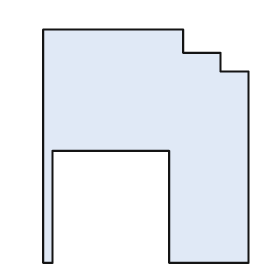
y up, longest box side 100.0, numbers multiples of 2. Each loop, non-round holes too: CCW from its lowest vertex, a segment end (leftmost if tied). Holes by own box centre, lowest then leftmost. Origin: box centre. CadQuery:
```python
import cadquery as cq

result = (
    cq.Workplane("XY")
    .moveTo(-44.0, -50.0)
    .lineTo(-40.0, -50.0)
    .lineTo(-40.0, -2.0)
    .lineTo(10.0, -2.0)
    .lineTo(10.0, -50.0)
    .lineTo(44.0, -50.0)
    .lineTo(44.0, 32.0)
    .lineTo(32.0, 32.0)
    .lineTo(32.0, 40.0)
    .lineTo(16.0, 40.0)
    .lineTo(16.0, 50.0)
    .lineTo(-44.0, 50.0)
    .close()
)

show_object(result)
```